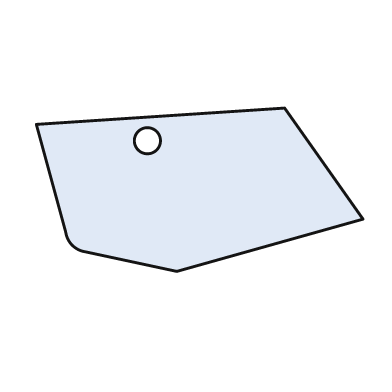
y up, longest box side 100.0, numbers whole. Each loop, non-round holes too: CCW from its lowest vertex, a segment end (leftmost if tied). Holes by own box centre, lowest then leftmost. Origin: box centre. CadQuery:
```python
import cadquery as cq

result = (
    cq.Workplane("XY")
    .moveTo(-7.0, -25.0)
    .lineTo(50.0, -9.0)
    .lineTo(26.0, 25.0)
    .lineTo(-50.0, 20.0)
    .lineTo(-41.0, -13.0)
    .threePointArc((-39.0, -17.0), (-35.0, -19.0))
    .close()
    .moveTo(-16.0, 15.0)
    .circle(4.0)
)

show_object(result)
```